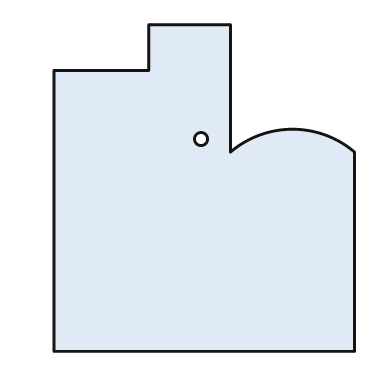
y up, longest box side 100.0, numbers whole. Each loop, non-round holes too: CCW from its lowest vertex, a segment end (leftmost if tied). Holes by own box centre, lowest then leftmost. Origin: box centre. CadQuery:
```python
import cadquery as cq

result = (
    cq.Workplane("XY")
    .moveTo(-46.0, -50.0)
    .lineTo(46.0, -50.0)
    .lineTo(46.0, 11.0)
    .threePointArc((27.0, 18.0), (8.0, 11.0))
    .lineTo(8.0, 50.0)
    .lineTo(-17.0, 50.0)
    .lineTo(-17.0, 36.0)
    .lineTo(-46.0, 36.0)
    .close()
    .moveTo(-1.0, 15.0)
    .circle(2.0)
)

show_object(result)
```